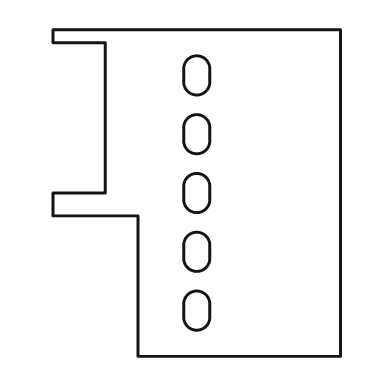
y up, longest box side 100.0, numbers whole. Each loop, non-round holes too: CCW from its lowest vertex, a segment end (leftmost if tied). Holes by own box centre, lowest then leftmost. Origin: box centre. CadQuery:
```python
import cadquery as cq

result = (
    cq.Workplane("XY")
    .moveTo(-18.0, -50.0)
    .lineTo(44.0, -50.0)
    .lineTo(44.0, 50.0)
    .lineTo(-44.0, 50.0)
    .lineTo(-44.0, 46.0)
    .lineTo(-28.0, 46.0)
    .lineTo(-28.0, 0.0)
    .lineTo(-44.0, 0.0)
    .lineTo(-44.0, -7.0)
    .lineTo(-18.0, -7.0)
    .close()
    .moveTo(-4.0, -38.0)
    .threePointArc((0.0, -42.0), (4.0, -38.0))
    .lineTo(4.0, -34.0)
    .threePointArc((0.0, -30.0), (-4.0, -34.0))
    .close()
    .moveTo(-4.0, -20.0)
    .threePointArc((0.0, -24.0), (4.0, -20.0))
    .lineTo(4.0, -16.0)
    .threePointArc((0.0, -12.0), (-4.0, -16.0))
    .close()
    .moveTo(-4.0, -2.0)
    .threePointArc((0.0, -6.0), (4.0, -2.0))
    .lineTo(4.0, 2.0)
    .threePointArc((0.0, 6.0), (-4.0, 2.0))
    .close()
    .moveTo(-4.0, 16.0)
    .threePointArc((0.0, 12.0), (4.0, 16.0))
    .lineTo(4.0, 20.0)
    .threePointArc((0.0, 24.0), (-4.0, 20.0))
    .close()
    .moveTo(-4.0, 34.0)
    .threePointArc((0.0, 30.0), (4.0, 34.0))
    .lineTo(4.0, 38.0)
    .threePointArc((0.0, 42.0), (-4.0, 38.0))
    .close()
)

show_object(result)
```